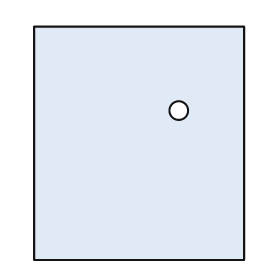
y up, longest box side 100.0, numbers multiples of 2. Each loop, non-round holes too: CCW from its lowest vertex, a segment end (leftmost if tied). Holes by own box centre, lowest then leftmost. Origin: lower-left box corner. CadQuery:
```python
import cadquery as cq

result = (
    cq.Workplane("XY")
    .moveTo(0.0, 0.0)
    .lineTo(90.0, 0.0)
    .lineTo(90.0, 100.0)
    .lineTo(0.0, 100.0)
    .close()
    .moveTo(62.0, 64.0)
    .circle(4.0)
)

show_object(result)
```